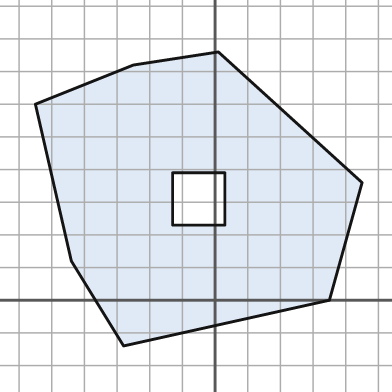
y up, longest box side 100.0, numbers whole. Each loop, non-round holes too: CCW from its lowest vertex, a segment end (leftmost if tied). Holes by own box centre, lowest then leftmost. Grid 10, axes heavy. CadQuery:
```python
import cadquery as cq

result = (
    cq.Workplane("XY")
    .moveTo(-28.0, -14.0)
    .lineTo(35.0, 0.0)
    .lineTo(45.0, 36.0)
    .lineTo(1.0, 76.0)
    .lineTo(-25.0, 72.0)
    .lineTo(-55.0, 60.0)
    .lineTo(-44.0, 12.0)
    .close()
    .moveTo(-13.0, 23.0)
    .lineTo(3.0, 23.0)
    .lineTo(3.0, 39.0)
    .lineTo(-13.0, 39.0)
    .close()
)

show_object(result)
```